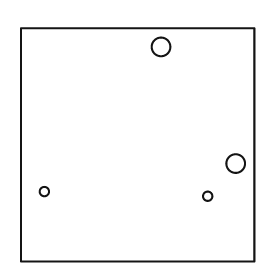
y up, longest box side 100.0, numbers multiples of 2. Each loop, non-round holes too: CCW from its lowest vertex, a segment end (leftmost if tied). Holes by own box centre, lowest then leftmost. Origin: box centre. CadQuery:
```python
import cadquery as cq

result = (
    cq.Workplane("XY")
    .moveTo(-50.0, -50.0)
    .lineTo(50.0, -50.0)
    .lineTo(50.0, 50.0)
    .lineTo(-50.0, 50.0)
    .close()
    .moveTo(30.0, -22.0)
    .circle(2.0)
    .moveTo(-40.0, -20.0)
    .circle(2.0)
    .moveTo(42.0, -8.0)
    .circle(4.0)
    .moveTo(10.0, 42.0)
    .circle(4.0)
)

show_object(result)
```